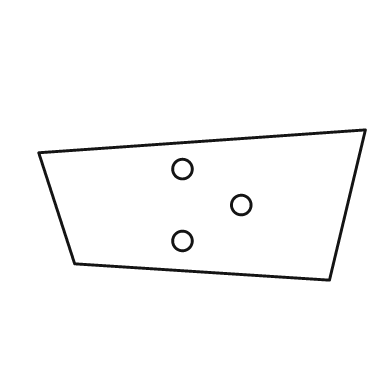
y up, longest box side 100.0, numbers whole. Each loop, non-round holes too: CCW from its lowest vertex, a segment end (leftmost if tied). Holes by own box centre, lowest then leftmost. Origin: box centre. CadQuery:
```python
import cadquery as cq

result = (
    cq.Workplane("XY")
    .moveTo(39.0, -23.0)
    .lineTo(50.0, 23.0)
    .lineTo(-50.0, 16.0)
    .lineTo(-39.0, -18.0)
    .close()
    .moveTo(-6.0, -11.0)
    .circle(3.0)
    .moveTo(12.0, 0.0)
    .circle(3.0)
    .moveTo(-6.0, 11.0)
    .circle(3.0)
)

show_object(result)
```